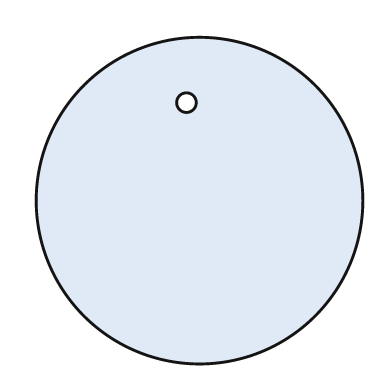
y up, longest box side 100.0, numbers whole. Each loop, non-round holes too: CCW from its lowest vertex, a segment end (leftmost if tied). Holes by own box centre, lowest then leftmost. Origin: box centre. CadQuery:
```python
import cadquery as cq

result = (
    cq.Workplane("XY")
    .moveTo(0.0, 0.0)
    .circle(50.0)
    .moveTo(-4.0, 30.0)
    .circle(3.0)
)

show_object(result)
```